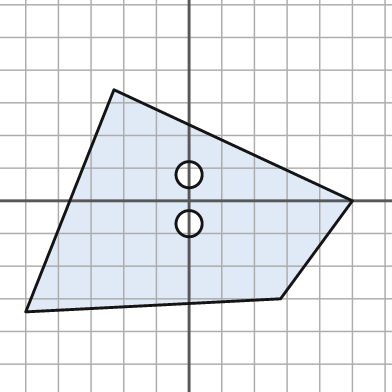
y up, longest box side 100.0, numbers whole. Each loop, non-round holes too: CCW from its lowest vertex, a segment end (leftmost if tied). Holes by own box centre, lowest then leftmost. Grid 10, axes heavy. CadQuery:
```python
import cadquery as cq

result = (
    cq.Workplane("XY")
    .moveTo(-50.0, -34.0)
    .lineTo(28.0, -30.0)
    .lineTo(50.0, 0.0)
    .lineTo(-23.0, 34.0)
    .close()
    .moveTo(0.0, -7.0)
    .circle(4.0)
    .moveTo(0.0, 8.0)
    .circle(4.0)
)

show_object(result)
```